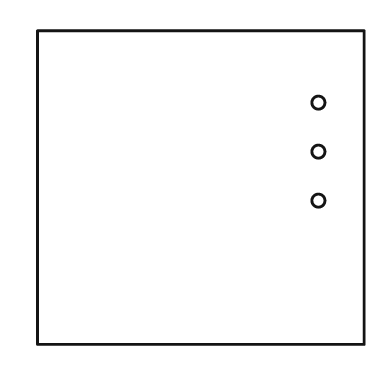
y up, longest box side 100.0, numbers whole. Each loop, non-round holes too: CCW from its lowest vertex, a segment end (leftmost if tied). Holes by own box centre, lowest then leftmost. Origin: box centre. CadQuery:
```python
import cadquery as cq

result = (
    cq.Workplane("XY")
    .moveTo(-50.0, -48.0)
    .lineTo(50.0, -48.0)
    .lineTo(50.0, 48.0)
    .lineTo(-50.0, 48.0)
    .close()
    .moveTo(36.0, -4.0)
    .circle(2.0)
    .moveTo(36.0, 11.0)
    .circle(2.0)
    .moveTo(36.0, 26.0)
    .circle(2.0)
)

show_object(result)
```